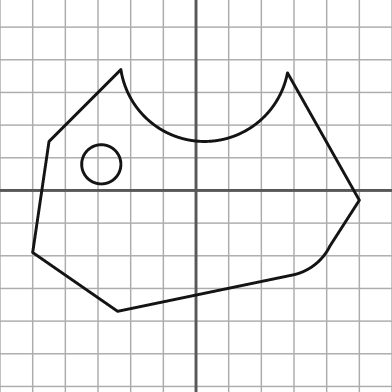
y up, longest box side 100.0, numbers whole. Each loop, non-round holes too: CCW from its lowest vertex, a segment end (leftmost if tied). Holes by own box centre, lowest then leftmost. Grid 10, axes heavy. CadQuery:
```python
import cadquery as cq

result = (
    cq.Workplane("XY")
    .moveTo(-24.0, -37.0)
    .lineTo(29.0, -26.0)
    .threePointArc((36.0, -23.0), (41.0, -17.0))
    .lineTo(50.0, -3.0)
    .lineTo(28.0, 36.0)
    .threePointArc((2.0, 15.0), (-23.0, 37.0))
    .lineTo(-45.0, 15.0)
    .lineTo(-50.0, -19.0)
    .close()
    .moveTo(-29.0, 8.0)
    .circle(6.0)
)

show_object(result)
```